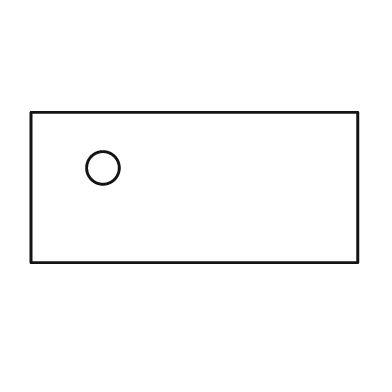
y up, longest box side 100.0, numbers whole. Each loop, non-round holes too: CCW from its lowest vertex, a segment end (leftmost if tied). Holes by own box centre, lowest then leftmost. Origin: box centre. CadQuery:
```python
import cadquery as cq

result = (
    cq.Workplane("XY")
    .moveTo(-50.0, -23.0)
    .lineTo(50.0, -23.0)
    .lineTo(50.0, 23.0)
    .lineTo(-50.0, 23.0)
    .close()
    .moveTo(-28.0, 6.0)
    .circle(5.0)
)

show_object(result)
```